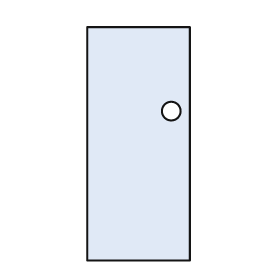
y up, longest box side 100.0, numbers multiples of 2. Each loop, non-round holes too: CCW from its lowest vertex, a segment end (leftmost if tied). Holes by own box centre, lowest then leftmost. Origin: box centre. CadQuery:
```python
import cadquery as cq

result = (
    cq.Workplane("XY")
    .moveTo(-22.0, -50.0)
    .lineTo(22.0, -50.0)
    .lineTo(22.0, 50.0)
    .lineTo(-22.0, 50.0)
    .close()
    .moveTo(14.0, 14.0)
    .circle(4.0)
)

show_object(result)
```